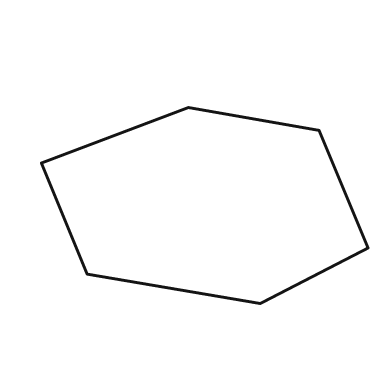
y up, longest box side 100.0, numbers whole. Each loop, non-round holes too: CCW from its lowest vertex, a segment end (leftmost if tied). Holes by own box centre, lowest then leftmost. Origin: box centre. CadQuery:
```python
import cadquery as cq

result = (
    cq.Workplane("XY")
    .moveTo(17.0, -30.0)
    .lineTo(50.0, -13.0)
    .lineTo(35.0, 23.0)
    .lineTo(-5.0, 30.0)
    .lineTo(-50.0, 13.0)
    .lineTo(-36.0, -21.0)
    .close()
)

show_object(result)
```